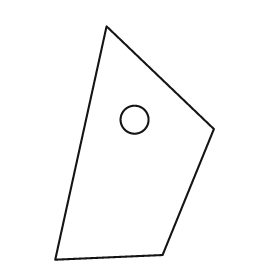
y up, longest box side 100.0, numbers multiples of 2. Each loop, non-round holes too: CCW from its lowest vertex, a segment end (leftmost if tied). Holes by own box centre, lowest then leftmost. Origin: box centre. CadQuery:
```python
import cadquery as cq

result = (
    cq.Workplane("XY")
    .moveTo(-34.0, -50.0)
    .lineTo(12.0, -48.0)
    .lineTo(34.0, 6.0)
    .lineTo(-12.0, 50.0)
    .close()
    .moveTo(0.0, 10.0)
    .circle(6.0)
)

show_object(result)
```